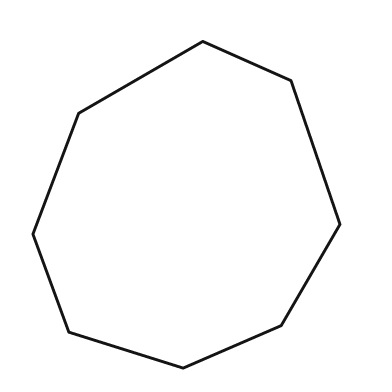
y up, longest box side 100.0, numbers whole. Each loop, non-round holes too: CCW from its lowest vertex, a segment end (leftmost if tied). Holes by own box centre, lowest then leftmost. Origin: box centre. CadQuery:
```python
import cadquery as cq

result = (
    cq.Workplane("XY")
    .moveTo(-1.0, -50.0)
    .lineTo(29.0, -37.0)
    .lineTo(47.0, -6.0)
    .lineTo(32.0, 38.0)
    .lineTo(5.0, 50.0)
    .lineTo(-33.0, 28.0)
    .lineTo(-47.0, -9.0)
    .lineTo(-36.0, -39.0)
    .close()
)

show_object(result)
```